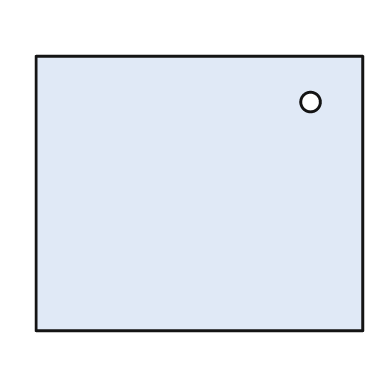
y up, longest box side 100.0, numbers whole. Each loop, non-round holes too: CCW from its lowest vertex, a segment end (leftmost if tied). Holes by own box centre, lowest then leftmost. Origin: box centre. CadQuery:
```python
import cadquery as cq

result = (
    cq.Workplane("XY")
    .moveTo(-50.0, -42.0)
    .lineTo(50.0, -42.0)
    .lineTo(50.0, 42.0)
    .lineTo(-50.0, 42.0)
    .close()
    .moveTo(34.0, 28.0)
    .circle(3.0)
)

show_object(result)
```